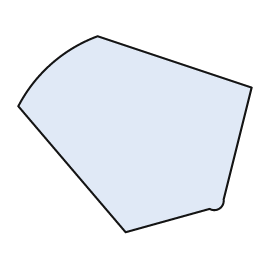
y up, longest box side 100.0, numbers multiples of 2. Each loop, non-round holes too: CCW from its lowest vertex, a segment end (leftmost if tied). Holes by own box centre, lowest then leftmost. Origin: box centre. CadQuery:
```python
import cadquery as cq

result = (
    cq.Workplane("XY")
    .moveTo(-4.0, -42.0)
    .lineTo(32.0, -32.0)
    .threePointArc((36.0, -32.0), (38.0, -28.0))
    .lineTo(50.0, 20.0)
    .lineTo(-16.0, 42.0)
    .threePointArc((-36.0, 30.0), (-50.0, 12.0))
    .close()
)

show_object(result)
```